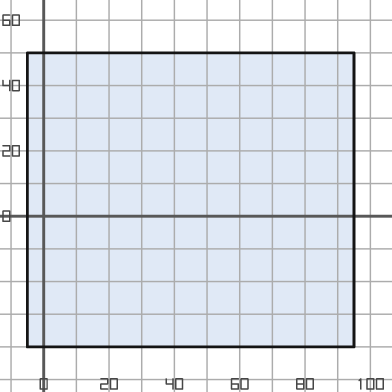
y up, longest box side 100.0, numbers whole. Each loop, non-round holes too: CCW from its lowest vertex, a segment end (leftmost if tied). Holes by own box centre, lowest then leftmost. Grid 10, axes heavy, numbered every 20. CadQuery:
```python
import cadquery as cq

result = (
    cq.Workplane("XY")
    .moveTo(-5.0, -40.0)
    .lineTo(95.0, -40.0)
    .lineTo(95.0, 50.0)
    .lineTo(-5.0, 50.0)
    .close()
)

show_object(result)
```